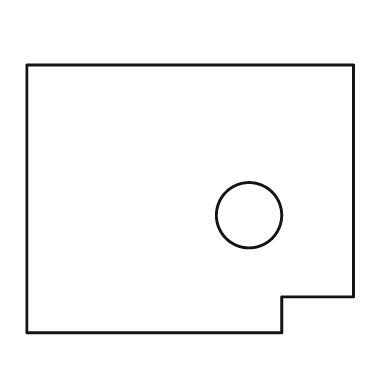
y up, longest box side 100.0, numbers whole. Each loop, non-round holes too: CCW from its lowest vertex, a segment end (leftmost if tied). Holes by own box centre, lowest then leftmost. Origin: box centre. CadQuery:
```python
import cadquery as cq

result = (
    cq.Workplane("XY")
    .moveTo(-50.0, -41.0)
    .lineTo(28.0, -41.0)
    .lineTo(28.0, -30.0)
    .lineTo(50.0, -30.0)
    .lineTo(50.0, 41.0)
    .lineTo(-50.0, 41.0)
    .close()
    .moveTo(18.0, -5.0)
    .circle(10.0)
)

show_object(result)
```